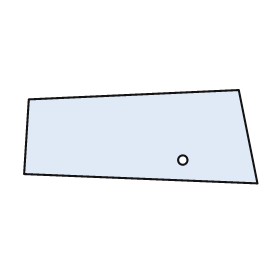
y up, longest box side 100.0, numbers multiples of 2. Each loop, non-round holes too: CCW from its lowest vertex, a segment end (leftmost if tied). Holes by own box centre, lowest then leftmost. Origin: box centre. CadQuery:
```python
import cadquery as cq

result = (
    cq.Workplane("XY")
    .moveTo(50.0, -20.0)
    .lineTo(42.0, 20.0)
    .lineTo(-48.0, 16.0)
    .lineTo(-50.0, -16.0)
    .close()
    .moveTo(18.0, -10.0)
    .circle(2.0)
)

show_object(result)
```